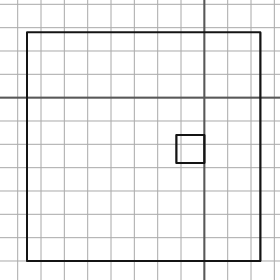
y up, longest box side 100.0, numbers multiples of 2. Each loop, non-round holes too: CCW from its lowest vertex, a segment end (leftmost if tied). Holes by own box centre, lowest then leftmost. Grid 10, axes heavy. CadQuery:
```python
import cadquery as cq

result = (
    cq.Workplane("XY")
    .moveTo(-76.0, -70.0)
    .lineTo(24.0, -70.0)
    .lineTo(24.0, 28.0)
    .lineTo(-76.0, 28.0)
    .close()
    .moveTo(-12.0, -28.0)
    .lineTo(0.0, -28.0)
    .lineTo(0.0, -16.0)
    .lineTo(-12.0, -16.0)
    .close()
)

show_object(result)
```